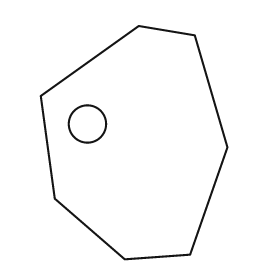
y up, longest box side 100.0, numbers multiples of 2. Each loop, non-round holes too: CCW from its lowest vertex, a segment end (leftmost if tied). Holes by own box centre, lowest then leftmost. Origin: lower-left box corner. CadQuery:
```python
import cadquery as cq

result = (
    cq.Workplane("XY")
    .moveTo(36.0, 0.0)
    .lineTo(64.0, 2.0)
    .lineTo(80.0, 48.0)
    .lineTo(66.0, 96.0)
    .lineTo(42.0, 100.0)
    .lineTo(0.0, 70.0)
    .lineTo(6.0, 26.0)
    .close()
    .moveTo(20.0, 58.0)
    .circle(8.0)
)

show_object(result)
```